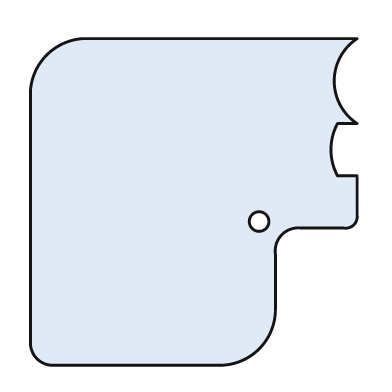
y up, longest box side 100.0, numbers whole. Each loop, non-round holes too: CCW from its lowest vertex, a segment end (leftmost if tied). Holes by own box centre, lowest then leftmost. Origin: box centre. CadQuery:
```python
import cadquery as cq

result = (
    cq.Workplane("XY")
    .moveTo(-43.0, -50.0)
    .lineTo(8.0, -50.0)
    .threePointArc((20.0, -45.0), (25.0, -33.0))
    .lineTo(25.0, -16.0)
    .threePointArc((27.0, -10.0), (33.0, -8.0))
    .lineTo(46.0, -8.0)
    .threePointArc((49.0, -7.0), (50.0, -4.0))
    .lineTo(50.0, 8.0)
    .lineTo(44.0, 8.0)
    .threePointArc((42.0, 16.0), (44.0, 24.0))
    .lineTo(50.0, 24.0)
    .threePointArc((43.0, 37.0), (50.0, 50.0))
    .lineTo(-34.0, 50.0)
    .threePointArc((-45.0, 45.0), (-50.0, 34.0))
    .lineTo(-50.0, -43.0)
    .threePointArc((-48.0, -48.0), (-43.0, -50.0))
    .close()
    .moveTo(20.0, -6.0)
    .circle(3.0)
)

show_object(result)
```